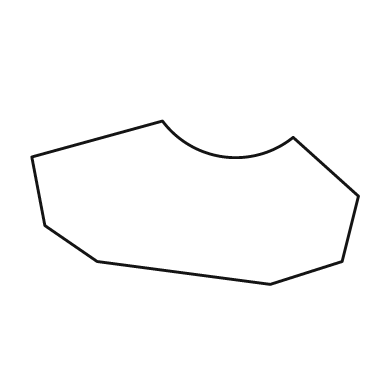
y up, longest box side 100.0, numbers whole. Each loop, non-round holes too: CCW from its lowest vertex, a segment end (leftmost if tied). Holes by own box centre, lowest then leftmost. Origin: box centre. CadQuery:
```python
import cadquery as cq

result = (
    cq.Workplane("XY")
    .moveTo(23.0, -25.0)
    .lineTo(45.0, -18.0)
    .lineTo(50.0, 2.0)
    .lineTo(30.0, 20.0)
    .threePointArc((9.0, 14.0), (-10.0, 25.0))
    .lineTo(-50.0, 14.0)
    .lineTo(-46.0, -7.0)
    .lineTo(-30.0, -18.0)
    .close()
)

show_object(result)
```